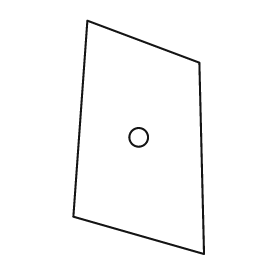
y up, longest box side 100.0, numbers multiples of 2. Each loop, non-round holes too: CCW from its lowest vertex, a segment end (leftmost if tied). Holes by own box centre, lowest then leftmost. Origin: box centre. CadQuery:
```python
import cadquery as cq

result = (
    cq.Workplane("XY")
    .moveTo(28.0, -50.0)
    .lineTo(26.0, 32.0)
    .lineTo(-22.0, 50.0)
    .lineTo(-28.0, -34.0)
    .close()
    .moveTo(0.0, 0.0)
    .circle(4.0)
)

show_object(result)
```